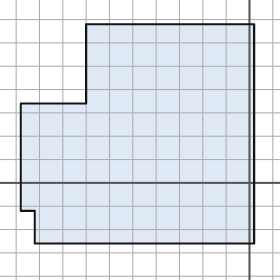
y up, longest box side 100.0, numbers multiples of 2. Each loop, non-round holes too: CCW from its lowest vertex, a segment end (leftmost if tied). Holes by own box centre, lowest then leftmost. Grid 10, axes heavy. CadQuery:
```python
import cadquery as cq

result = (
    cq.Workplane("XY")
    .moveTo(-92.0, -26.0)
    .lineTo(2.0, -26.0)
    .lineTo(2.0, 68.0)
    .lineTo(-70.0, 68.0)
    .lineTo(-70.0, 34.0)
    .lineTo(-98.0, 34.0)
    .lineTo(-98.0, -12.0)
    .lineTo(-92.0, -12.0)
    .close()
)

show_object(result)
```